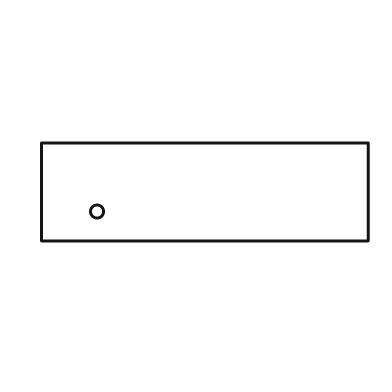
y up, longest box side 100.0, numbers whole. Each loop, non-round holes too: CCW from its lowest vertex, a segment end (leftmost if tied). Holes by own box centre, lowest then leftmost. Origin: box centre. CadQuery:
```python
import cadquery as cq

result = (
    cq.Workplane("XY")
    .moveTo(-50.0, -15.0)
    .lineTo(50.0, -15.0)
    .lineTo(50.0, 15.0)
    .lineTo(-50.0, 15.0)
    .close()
    .moveTo(-33.0, -6.0)
    .circle(2.0)
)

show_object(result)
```